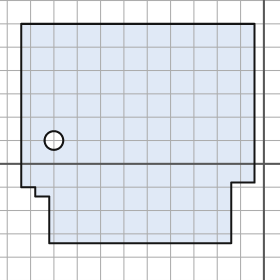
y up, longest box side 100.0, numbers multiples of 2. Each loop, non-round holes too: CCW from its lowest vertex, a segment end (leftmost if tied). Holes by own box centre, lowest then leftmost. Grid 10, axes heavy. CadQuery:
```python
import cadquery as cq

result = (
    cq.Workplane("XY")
    .moveTo(-92.0, -34.0)
    .lineTo(-14.0, -34.0)
    .lineTo(-14.0, -8.0)
    .lineTo(-4.0, -8.0)
    .lineTo(-4.0, 60.0)
    .lineTo(-104.0, 60.0)
    .lineTo(-104.0, -10.0)
    .lineTo(-98.0, -10.0)
    .lineTo(-98.0, -14.0)
    .lineTo(-92.0, -14.0)
    .close()
    .moveTo(-90.0, 10.0)
    .circle(4.0)
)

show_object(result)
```